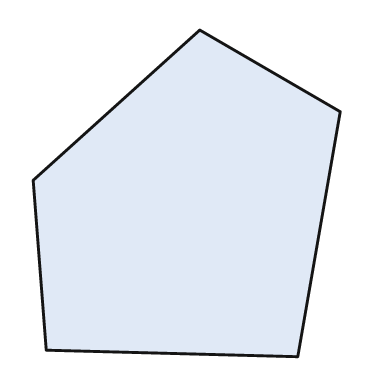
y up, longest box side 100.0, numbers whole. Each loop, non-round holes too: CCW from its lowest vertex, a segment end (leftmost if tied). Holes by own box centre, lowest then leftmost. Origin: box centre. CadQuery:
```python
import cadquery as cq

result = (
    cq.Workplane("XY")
    .moveTo(34.0, -50.0)
    .lineTo(47.0, 25.0)
    .lineTo(4.0, 50.0)
    .lineTo(-47.0, 4.0)
    .lineTo(-43.0, -48.0)
    .close()
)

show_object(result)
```